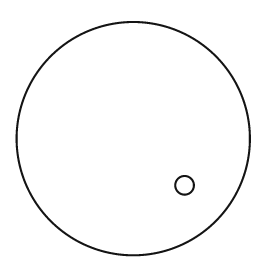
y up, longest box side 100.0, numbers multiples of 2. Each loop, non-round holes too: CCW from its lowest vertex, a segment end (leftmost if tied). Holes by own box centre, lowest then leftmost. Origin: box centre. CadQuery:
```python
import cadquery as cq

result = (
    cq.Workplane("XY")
    .moveTo(0.0, 0.0)
    .circle(50.0)
    .moveTo(22.0, -20.0)
    .circle(4.0)
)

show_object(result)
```